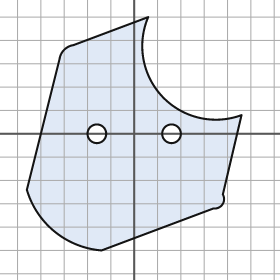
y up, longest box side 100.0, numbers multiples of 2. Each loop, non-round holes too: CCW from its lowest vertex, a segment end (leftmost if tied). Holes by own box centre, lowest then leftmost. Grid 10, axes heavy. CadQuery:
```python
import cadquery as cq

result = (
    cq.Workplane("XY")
    .moveTo(-14.0, -50.0)
    .lineTo(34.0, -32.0)
    .threePointArc((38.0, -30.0), (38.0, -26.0))
    .lineTo(46.0, 8.0)
    .threePointArc((12.0, 16.0), (6.0, 50.0))
    .lineTo(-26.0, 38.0)
    .threePointArc((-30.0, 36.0), (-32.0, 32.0))
    .lineTo(-46.0, -24.0)
    .threePointArc((-34.0, -42.0), (-14.0, -50.0))
    .close()
    .moveTo(-16.0, 0.0)
    .circle(4.0)
    .moveTo(16.0, 0.0)
    .circle(4.0)
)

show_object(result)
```